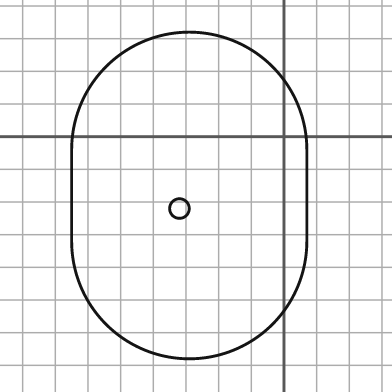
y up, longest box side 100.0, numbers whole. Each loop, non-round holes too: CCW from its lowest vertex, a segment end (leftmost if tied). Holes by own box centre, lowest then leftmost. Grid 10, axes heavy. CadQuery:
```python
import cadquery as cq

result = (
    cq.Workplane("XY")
    .moveTo(-65.0, -32.0)
    .threePointArc((-29.0, -68.0), (7.0, -32.0))
    .lineTo(7.0, -4.0)
    .threePointArc((-29.0, 32.0), (-65.0, -4.0))
    .close()
    .moveTo(-32.0, -22.0)
    .circle(3.0)
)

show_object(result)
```